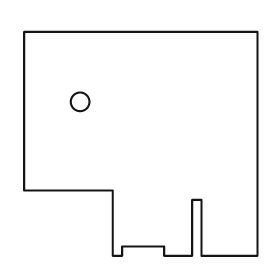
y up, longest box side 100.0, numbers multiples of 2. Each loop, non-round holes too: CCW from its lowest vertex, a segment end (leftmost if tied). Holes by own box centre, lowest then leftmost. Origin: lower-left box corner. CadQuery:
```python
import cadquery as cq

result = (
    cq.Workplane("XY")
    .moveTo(38.0, 0.0)
    .lineTo(42.0, 0.0)
    .lineTo(42.0, 4.0)
    .lineTo(60.0, 4.0)
    .lineTo(60.0, 0.0)
    .lineTo(72.0, 0.0)
    .lineTo(72.0, 24.0)
    .lineTo(76.0, 24.0)
    .lineTo(76.0, 0.0)
    .lineTo(100.0, 0.0)
    .lineTo(100.0, 96.0)
    .lineTo(0.0, 96.0)
    .lineTo(0.0, 28.0)
    .lineTo(38.0, 28.0)
    .close()
    .moveTo(24.0, 66.0)
    .circle(4.0)
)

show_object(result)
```